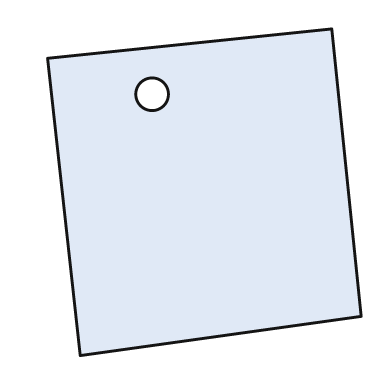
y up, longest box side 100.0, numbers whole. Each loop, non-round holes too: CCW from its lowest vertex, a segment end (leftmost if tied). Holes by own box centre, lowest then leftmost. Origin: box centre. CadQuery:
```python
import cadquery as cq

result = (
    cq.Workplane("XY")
    .moveTo(-38.0, -50.0)
    .lineTo(48.0, -38.0)
    .lineTo(39.0, 50.0)
    .lineTo(-48.0, 41.0)
    .close()
    .moveTo(-16.0, 30.0)
    .circle(5.0)
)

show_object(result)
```